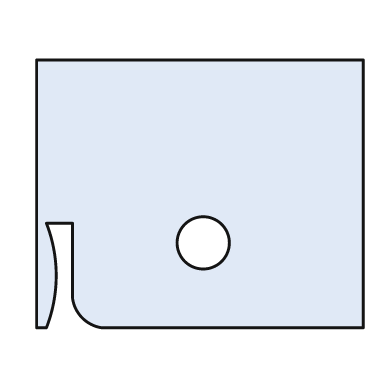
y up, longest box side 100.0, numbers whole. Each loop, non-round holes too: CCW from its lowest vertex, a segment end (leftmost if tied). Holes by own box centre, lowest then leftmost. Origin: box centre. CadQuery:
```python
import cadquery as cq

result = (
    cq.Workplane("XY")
    .moveTo(-50.0, -41.0)
    .lineTo(-47.0, -41.0)
    .threePointArc((-44.0, -25.0), (-47.0, -9.0))
    .lineTo(-39.0, -9.0)
    .lineTo(-39.0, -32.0)
    .threePointArc((-36.0, -38.0), (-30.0, -41.0))
    .lineTo(50.0, -41.0)
    .lineTo(50.0, 41.0)
    .lineTo(-50.0, 41.0)
    .close()
    .moveTo(1.0, -15.0)
    .circle(8.0)
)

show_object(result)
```